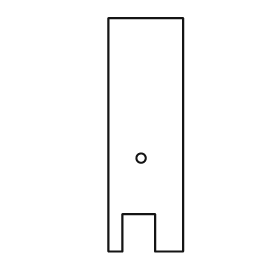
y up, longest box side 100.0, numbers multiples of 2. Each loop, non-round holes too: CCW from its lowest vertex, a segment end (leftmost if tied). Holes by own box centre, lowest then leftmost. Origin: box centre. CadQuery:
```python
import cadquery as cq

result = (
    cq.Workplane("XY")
    .moveTo(-16.0, -50.0)
    .lineTo(-10.0, -50.0)
    .lineTo(-10.0, -34.0)
    .lineTo(4.0, -34.0)
    .lineTo(4.0, -50.0)
    .lineTo(16.0, -50.0)
    .lineTo(16.0, 50.0)
    .lineTo(-16.0, 50.0)
    .close()
    .moveTo(-2.0, -10.0)
    .circle(2.0)
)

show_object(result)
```